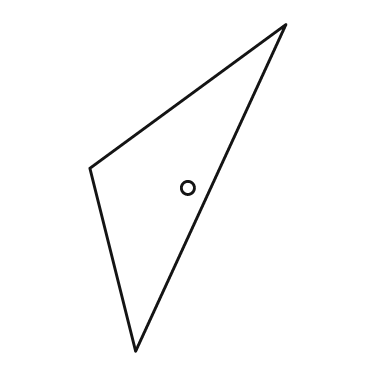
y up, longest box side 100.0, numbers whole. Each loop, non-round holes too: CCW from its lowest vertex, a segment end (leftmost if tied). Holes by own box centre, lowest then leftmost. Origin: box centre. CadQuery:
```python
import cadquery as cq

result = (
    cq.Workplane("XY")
    .moveTo(-16.0, -50.0)
    .lineTo(30.0, 50.0)
    .lineTo(-30.0, 6.0)
    .close()
    .moveTo(0.0, 0.0)
    .circle(2.0)
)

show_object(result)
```